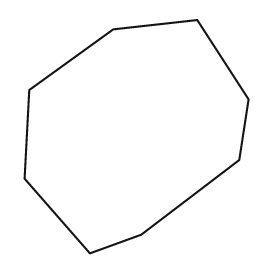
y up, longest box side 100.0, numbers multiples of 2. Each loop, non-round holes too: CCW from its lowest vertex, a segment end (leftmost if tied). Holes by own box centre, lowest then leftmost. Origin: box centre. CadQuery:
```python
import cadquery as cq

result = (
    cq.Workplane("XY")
    .moveTo(-20.0, -50.0)
    .lineTo(2.0, -42.0)
    .lineTo(44.0, -10.0)
    .lineTo(48.0, 16.0)
    .lineTo(26.0, 50.0)
    .lineTo(-10.0, 46.0)
    .lineTo(-46.0, 20.0)
    .lineTo(-48.0, -18.0)
    .close()
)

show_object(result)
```